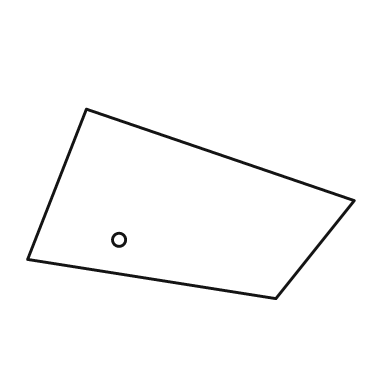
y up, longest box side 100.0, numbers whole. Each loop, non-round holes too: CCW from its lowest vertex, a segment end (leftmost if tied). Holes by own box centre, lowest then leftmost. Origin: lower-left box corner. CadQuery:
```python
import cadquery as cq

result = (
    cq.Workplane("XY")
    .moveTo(76.0, 0.0)
    .lineTo(100.0, 30.0)
    .lineTo(18.0, 58.0)
    .lineTo(0.0, 12.0)
    .close()
    .moveTo(28.0, 18.0)
    .circle(2.0)
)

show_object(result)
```